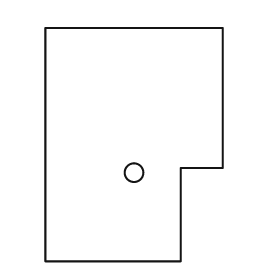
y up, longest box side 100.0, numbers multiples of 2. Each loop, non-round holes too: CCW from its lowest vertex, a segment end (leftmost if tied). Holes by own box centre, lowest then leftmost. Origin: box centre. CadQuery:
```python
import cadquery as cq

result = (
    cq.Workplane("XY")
    .moveTo(-38.0, -50.0)
    .lineTo(20.0, -50.0)
    .lineTo(20.0, -10.0)
    .lineTo(38.0, -10.0)
    .lineTo(38.0, 50.0)
    .lineTo(-38.0, 50.0)
    .close()
    .moveTo(0.0, -12.0)
    .circle(4.0)
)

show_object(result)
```